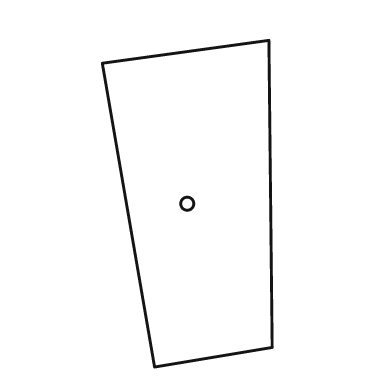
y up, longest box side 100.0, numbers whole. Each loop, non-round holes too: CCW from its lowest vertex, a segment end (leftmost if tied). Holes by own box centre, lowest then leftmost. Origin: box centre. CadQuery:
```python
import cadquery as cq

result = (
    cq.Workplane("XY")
    .moveTo(-10.0, -50.0)
    .lineTo(26.0, -44.0)
    .lineTo(25.0, 50.0)
    .lineTo(-26.0, 43.0)
    .close()
    .moveTo(0.0, 0.0)
    .circle(2.0)
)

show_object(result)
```